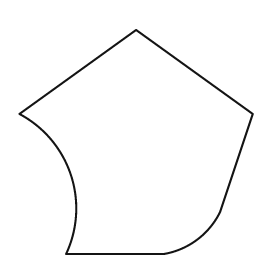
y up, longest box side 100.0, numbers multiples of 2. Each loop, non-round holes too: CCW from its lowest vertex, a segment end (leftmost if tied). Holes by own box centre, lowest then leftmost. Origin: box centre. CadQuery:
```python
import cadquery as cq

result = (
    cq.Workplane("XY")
    .moveTo(-30.0, -48.0)
    .lineTo(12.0, -48.0)
    .threePointArc((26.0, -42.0), (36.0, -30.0))
    .lineTo(50.0, 12.0)
    .lineTo(0.0, 48.0)
    .lineTo(-50.0, 12.0)
    .threePointArc((-28.0, -14.0), (-30.0, -48.0))
    .close()
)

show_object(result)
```